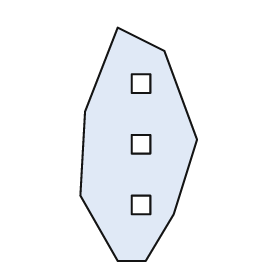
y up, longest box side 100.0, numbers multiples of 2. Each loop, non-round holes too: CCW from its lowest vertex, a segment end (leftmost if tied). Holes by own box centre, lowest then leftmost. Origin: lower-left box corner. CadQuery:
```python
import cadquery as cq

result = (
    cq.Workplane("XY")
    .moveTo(16.0, 0.0)
    .lineTo(28.0, 0.0)
    .lineTo(40.0, 20.0)
    .lineTo(50.0, 52.0)
    .lineTo(36.0, 90.0)
    .lineTo(16.0, 100.0)
    .lineTo(2.0, 64.0)
    .lineTo(0.0, 28.0)
    .close()
    .moveTo(22.0, 20.0)
    .lineTo(30.0, 20.0)
    .lineTo(30.0, 28.0)
    .lineTo(22.0, 28.0)
    .close()
    .moveTo(22.0, 46.0)
    .lineTo(30.0, 46.0)
    .lineTo(30.0, 54.0)
    .lineTo(22.0, 54.0)
    .close()
    .moveTo(22.0, 72.0)
    .lineTo(30.0, 72.0)
    .lineTo(30.0, 80.0)
    .lineTo(22.0, 80.0)
    .close()
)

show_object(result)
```